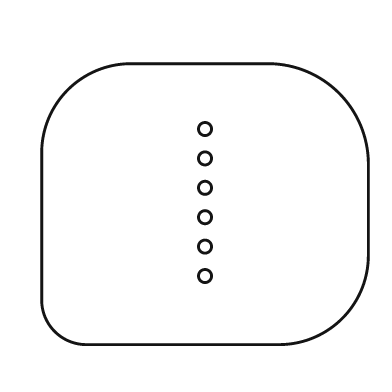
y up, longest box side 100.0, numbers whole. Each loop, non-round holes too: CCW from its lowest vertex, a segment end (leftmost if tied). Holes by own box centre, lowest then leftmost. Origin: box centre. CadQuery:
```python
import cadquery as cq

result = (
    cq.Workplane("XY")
    .moveTo(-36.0, -43.0)
    .lineTo(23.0, -43.0)
    .threePointArc((42.0, -35.0), (50.0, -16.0))
    .lineTo(50.0, 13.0)
    .threePointArc((41.0, 34.0), (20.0, 43.0))
    .lineTo(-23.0, 43.0)
    .threePointArc((-42.0, 35.0), (-50.0, 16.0))
    .lineTo(-50.0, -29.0)
    .threePointArc((-46.0, -39.0), (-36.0, -43.0))
    .close()
    .moveTo(0.0, -22.0)
    .circle(2.0)
    .moveTo(0.0, -13.0)
    .circle(2.0)
    .moveTo(0.0, -4.0)
    .circle(2.0)
    .moveTo(0.0, 5.0)
    .circle(2.0)
    .moveTo(0.0, 14.0)
    .circle(2.0)
    .moveTo(0.0, 23.0)
    .circle(2.0)
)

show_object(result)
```